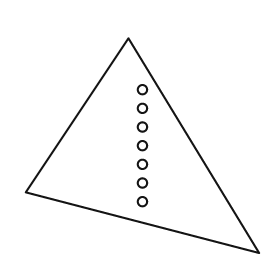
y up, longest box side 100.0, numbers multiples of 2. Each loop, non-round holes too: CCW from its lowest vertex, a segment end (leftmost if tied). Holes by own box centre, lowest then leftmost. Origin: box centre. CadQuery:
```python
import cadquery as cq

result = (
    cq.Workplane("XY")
    .moveTo(50.0, -46.0)
    .lineTo(-6.0, 46.0)
    .lineTo(-50.0, -20.0)
    .close()
    .moveTo(0.0, -24.0)
    .circle(2.0)
    .moveTo(0.0, -16.0)
    .circle(2.0)
    .moveTo(0.0, -8.0)
    .circle(2.0)
    .moveTo(0.0, 0.0)
    .circle(2.0)
    .moveTo(0.0, 8.0)
    .circle(2.0)
    .moveTo(0.0, 16.0)
    .circle(2.0)
    .moveTo(0.0, 24.0)
    .circle(2.0)
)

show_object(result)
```